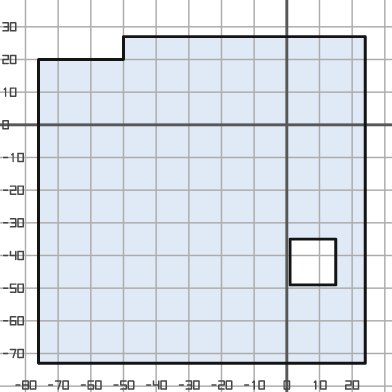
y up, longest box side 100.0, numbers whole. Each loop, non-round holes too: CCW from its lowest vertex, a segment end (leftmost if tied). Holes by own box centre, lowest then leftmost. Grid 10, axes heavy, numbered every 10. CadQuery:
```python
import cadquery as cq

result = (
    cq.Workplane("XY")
    .moveTo(-76.0, -73.0)
    .lineTo(24.0, -73.0)
    .lineTo(24.0, 27.0)
    .lineTo(-50.0, 27.0)
    .lineTo(-50.0, 20.0)
    .lineTo(-76.0, 20.0)
    .close()
    .moveTo(1.0, -49.0)
    .lineTo(15.0, -49.0)
    .lineTo(15.0, -35.0)
    .lineTo(1.0, -35.0)
    .close()
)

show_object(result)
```